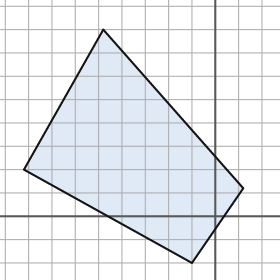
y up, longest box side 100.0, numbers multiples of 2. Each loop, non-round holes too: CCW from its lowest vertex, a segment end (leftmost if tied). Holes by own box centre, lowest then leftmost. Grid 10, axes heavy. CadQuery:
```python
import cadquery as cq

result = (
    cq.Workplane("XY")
    .moveTo(-10.0, -20.0)
    .lineTo(12.0, 12.0)
    .lineTo(-48.0, 80.0)
    .lineTo(-82.0, 20.0)
    .close()
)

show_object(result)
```